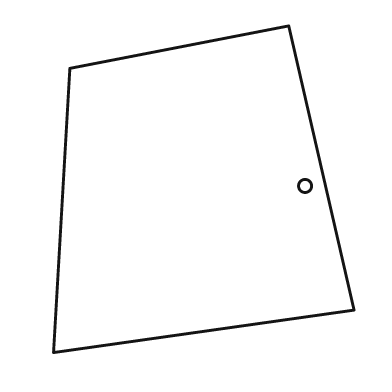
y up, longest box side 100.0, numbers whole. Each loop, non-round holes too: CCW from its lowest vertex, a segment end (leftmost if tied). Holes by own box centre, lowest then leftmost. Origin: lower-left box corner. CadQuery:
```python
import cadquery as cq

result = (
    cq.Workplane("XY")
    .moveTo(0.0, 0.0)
    .lineTo(92.0, 13.0)
    .lineTo(72.0, 100.0)
    .lineTo(5.0, 87.0)
    .close()
    .moveTo(77.0, 51.0)
    .circle(2.0)
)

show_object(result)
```